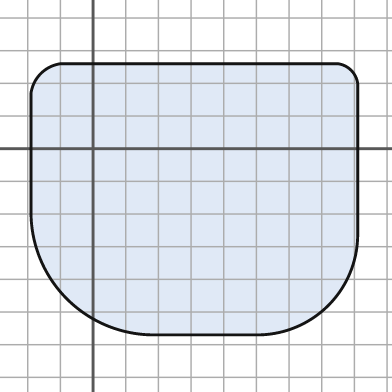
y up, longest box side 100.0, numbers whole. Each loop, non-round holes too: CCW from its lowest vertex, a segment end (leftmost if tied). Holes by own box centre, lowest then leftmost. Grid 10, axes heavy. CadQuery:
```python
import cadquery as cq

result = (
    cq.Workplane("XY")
    .moveTo(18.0, -57.0)
    .lineTo(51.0, -57.0)
    .threePointArc((72.0, -48.0), (81.0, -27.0))
    .lineTo(81.0, 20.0)
    .threePointArc((79.0, 24.0), (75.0, 26.0))
    .lineTo(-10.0, 26.0)
    .threePointArc((-16.0, 23.0), (-19.0, 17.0))
    .lineTo(-19.0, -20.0)
    .threePointArc((-8.0, -46.0), (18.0, -57.0))
    .close()
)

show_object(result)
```